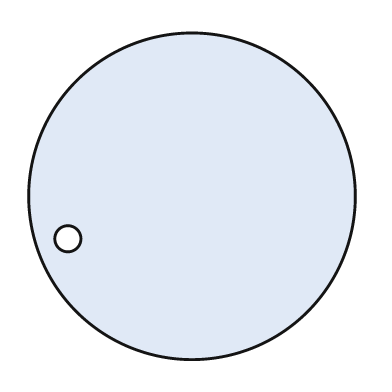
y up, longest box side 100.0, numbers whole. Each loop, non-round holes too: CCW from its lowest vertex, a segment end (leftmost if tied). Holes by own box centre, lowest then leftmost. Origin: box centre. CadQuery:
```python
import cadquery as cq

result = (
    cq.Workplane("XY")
    .moveTo(0.0, 0.0)
    .circle(50.0)
    .moveTo(-38.0, -13.0)
    .circle(4.0)
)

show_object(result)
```